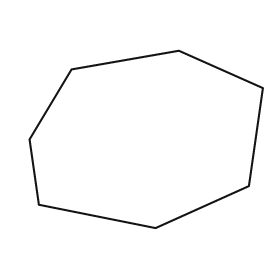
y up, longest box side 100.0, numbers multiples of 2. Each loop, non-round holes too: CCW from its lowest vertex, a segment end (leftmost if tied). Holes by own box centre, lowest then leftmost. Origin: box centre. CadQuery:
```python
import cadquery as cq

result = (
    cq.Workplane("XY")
    .moveTo(4.0, -38.0)
    .lineTo(44.0, -20.0)
    .lineTo(50.0, 22.0)
    .lineTo(14.0, 38.0)
    .lineTo(-32.0, 30.0)
    .lineTo(-50.0, 0.0)
    .lineTo(-46.0, -28.0)
    .close()
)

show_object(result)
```